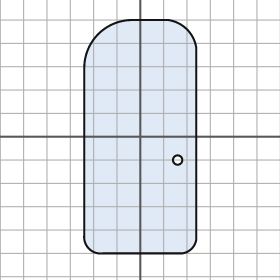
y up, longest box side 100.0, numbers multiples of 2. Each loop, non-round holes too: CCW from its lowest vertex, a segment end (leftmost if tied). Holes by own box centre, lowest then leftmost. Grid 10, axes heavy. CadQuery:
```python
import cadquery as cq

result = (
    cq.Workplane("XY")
    .moveTo(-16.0, -50.0)
    .lineTo(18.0, -50.0)
    .threePointArc((22.0, -48.0), (24.0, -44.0))
    .lineTo(24.0, 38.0)
    .threePointArc((20.0, 46.0), (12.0, 50.0))
    .lineTo(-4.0, 50.0)
    .threePointArc((-18.0, 44.0), (-24.0, 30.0))
    .lineTo(-24.0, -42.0)
    .threePointArc((-22.0, -48.0), (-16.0, -50.0))
    .close()
    .moveTo(16.0, -10.0)
    .circle(2.0)
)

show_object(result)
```